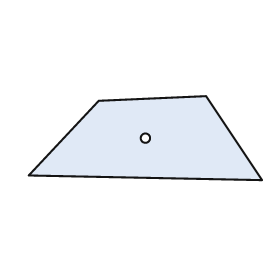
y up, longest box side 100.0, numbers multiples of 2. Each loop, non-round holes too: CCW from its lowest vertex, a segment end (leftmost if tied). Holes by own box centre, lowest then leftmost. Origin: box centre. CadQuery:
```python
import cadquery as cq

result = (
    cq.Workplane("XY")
    .moveTo(50.0, -18.0)
    .lineTo(26.0, 18.0)
    .lineTo(-20.0, 16.0)
    .lineTo(-50.0, -16.0)
    .close()
    .moveTo(0.0, 0.0)
    .circle(2.0)
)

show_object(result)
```